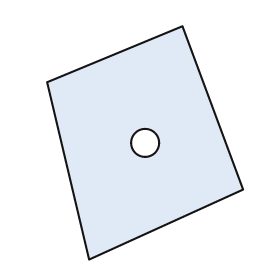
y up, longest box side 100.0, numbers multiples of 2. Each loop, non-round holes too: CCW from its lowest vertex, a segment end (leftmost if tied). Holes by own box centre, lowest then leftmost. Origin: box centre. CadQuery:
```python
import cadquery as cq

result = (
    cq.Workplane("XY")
    .moveTo(-24.0, -50.0)
    .lineTo(42.0, -20.0)
    .lineTo(16.0, 50.0)
    .lineTo(-42.0, 26.0)
    .close()
    .moveTo(0.0, 0.0)
    .circle(6.0)
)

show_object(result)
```